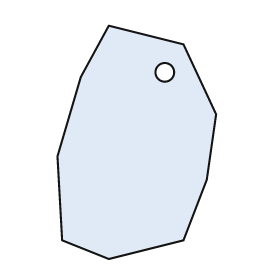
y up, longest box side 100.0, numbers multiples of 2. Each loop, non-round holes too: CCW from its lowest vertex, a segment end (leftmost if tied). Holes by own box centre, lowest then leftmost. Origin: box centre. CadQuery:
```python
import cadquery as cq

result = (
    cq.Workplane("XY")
    .moveTo(-12.0, -50.0)
    .lineTo(20.0, -42.0)
    .lineTo(30.0, -16.0)
    .lineTo(34.0, 12.0)
    .lineTo(20.0, 42.0)
    .lineTo(-12.0, 50.0)
    .lineTo(-24.0, 28.0)
    .lineTo(-34.0, -6.0)
    .lineTo(-32.0, -42.0)
    .close()
    .moveTo(12.0, 30.0)
    .circle(4.0)
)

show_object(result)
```